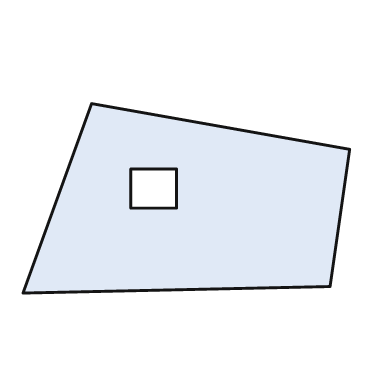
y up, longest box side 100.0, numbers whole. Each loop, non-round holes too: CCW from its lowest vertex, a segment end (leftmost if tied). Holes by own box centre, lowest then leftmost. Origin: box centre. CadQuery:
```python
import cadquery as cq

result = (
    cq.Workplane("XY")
    .moveTo(-50.0, -29.0)
    .lineTo(44.0, -27.0)
    .lineTo(50.0, 15.0)
    .lineTo(-29.0, 29.0)
    .close()
    .moveTo(-17.0, -3.0)
    .lineTo(-3.0, -3.0)
    .lineTo(-3.0, 9.0)
    .lineTo(-17.0, 9.0)
    .close()
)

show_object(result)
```